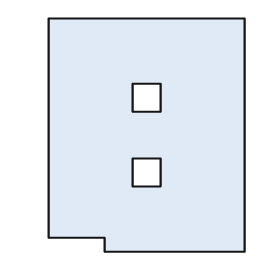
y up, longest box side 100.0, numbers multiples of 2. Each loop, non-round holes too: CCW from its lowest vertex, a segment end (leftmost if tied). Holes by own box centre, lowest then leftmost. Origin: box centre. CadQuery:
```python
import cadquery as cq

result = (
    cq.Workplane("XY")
    .moveTo(-18.0, -50.0)
    .lineTo(42.0, -50.0)
    .lineTo(42.0, 50.0)
    .lineTo(-42.0, 50.0)
    .lineTo(-42.0, -44.0)
    .lineTo(-18.0, -44.0)
    .close()
    .moveTo(-6.0, -22.0)
    .lineTo(6.0, -22.0)
    .lineTo(6.0, -10.0)
    .lineTo(-6.0, -10.0)
    .close()
    .moveTo(-6.0, 10.0)
    .lineTo(6.0, 10.0)
    .lineTo(6.0, 22.0)
    .lineTo(-6.0, 22.0)
    .close()
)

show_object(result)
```